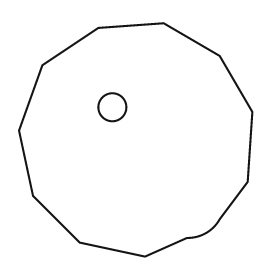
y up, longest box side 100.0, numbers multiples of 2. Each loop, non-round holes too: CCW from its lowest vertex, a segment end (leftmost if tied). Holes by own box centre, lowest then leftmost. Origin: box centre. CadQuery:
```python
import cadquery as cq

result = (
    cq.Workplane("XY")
    .moveTo(4.0, -50.0)
    .lineTo(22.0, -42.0)
    .threePointArc((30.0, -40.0), (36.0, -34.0))
    .lineTo(48.0, -18.0)
    .lineTo(50.0, 12.0)
    .lineTo(36.0, 36.0)
    .lineTo(12.0, 50.0)
    .lineTo(-16.0, 48.0)
    .lineTo(-40.0, 32.0)
    .lineTo(-50.0, 4.0)
    .lineTo(-44.0, -24.0)
    .lineTo(-24.0, -44.0)
    .close()
    .moveTo(-10.0, 14.0)
    .circle(6.0)
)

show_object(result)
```